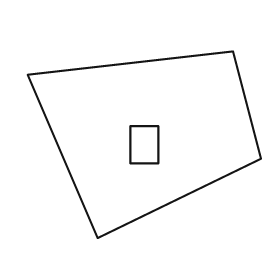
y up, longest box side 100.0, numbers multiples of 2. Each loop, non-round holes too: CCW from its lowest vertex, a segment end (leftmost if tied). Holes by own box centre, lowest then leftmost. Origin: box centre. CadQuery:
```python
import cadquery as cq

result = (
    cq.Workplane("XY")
    .moveTo(-20.0, -40.0)
    .lineTo(50.0, -6.0)
    .lineTo(38.0, 40.0)
    .lineTo(-50.0, 30.0)
    .close()
    .moveTo(-6.0, -8.0)
    .lineTo(6.0, -8.0)
    .lineTo(6.0, 8.0)
    .lineTo(-6.0, 8.0)
    .close()
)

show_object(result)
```